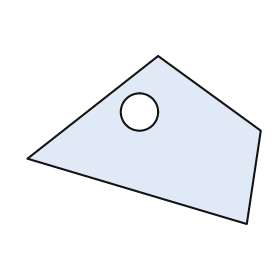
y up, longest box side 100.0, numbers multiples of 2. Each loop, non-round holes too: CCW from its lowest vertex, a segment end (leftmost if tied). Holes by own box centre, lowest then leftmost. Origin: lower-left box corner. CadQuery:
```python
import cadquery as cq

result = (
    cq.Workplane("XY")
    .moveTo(94.0, 0.0)
    .lineTo(100.0, 40.0)
    .lineTo(56.0, 72.0)
    .lineTo(0.0, 28.0)
    .close()
    .moveTo(48.0, 48.0)
    .circle(8.0)
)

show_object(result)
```